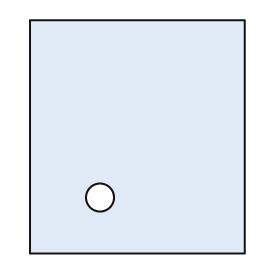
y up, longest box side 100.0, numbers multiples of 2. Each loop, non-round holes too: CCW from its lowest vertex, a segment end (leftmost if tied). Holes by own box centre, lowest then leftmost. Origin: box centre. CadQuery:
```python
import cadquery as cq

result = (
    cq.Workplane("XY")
    .moveTo(-46.0, -50.0)
    .lineTo(46.0, -50.0)
    .lineTo(46.0, 50.0)
    .lineTo(-46.0, 50.0)
    .close()
    .moveTo(-16.0, -26.0)
    .circle(6.0)
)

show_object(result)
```